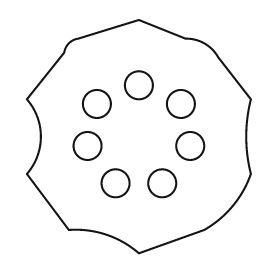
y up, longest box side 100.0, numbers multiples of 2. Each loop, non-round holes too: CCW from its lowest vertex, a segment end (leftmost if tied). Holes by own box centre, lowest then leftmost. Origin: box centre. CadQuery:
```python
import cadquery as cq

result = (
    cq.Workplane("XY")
    .moveTo(0.0, -50.0)
    .lineTo(28.0, -40.0)
    .threePointArc((40.0, -30.0), (48.0, -16.0))
    .threePointArc((46.0, 0.0), (48.0, 16.0))
    .lineTo(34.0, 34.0)
    .threePointArc((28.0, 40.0), (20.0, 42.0))
    .lineTo(0.0, 50.0)
    .lineTo(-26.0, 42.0)
    .threePointArc((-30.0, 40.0), (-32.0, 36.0))
    .lineTo(-48.0, 16.0)
    .threePointArc((-42.0, 0.0), (-48.0, -16.0))
    .lineTo(-30.0, -40.0)
    .threePointArc((-14.0, -42.0), (0.0, -50.0))
    .close()
    .moveTo(-10.0, -20.0)
    .circle(6.0)
    .moveTo(10.0, -20.0)
    .circle(6.0)
    .moveTo(-22.0, -4.0)
    .circle(6.0)
    .moveTo(22.0, -4.0)
    .circle(6.0)
    .moveTo(-18.0, 14.0)
    .circle(6.0)
    .moveTo(18.0, 14.0)
    .circle(6.0)
    .moveTo(0.0, 22.0)
    .circle(6.0)
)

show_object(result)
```